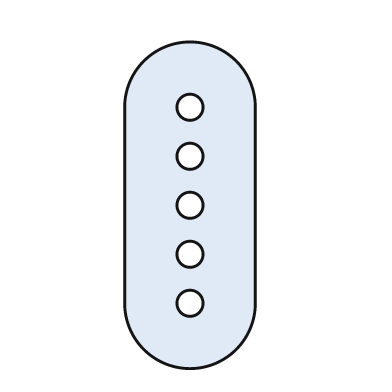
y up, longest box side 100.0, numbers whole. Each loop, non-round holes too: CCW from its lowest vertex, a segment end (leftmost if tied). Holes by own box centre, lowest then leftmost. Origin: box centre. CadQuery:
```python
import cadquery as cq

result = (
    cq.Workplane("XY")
    .moveTo(-20.0, -30.0)
    .threePointArc((0.0, -50.0), (20.0, -30.0))
    .lineTo(20.0, 30.0)
    .threePointArc((0.0, 50.0), (-20.0, 30.0))
    .close()
    .moveTo(0.0, -30.0)
    .circle(4.0)
    .moveTo(0.0, -15.0)
    .circle(4.0)
    .moveTo(0.0, 0.0)
    .circle(4.0)
    .moveTo(0.0, 15.0)
    .circle(4.0)
    .moveTo(0.0, 30.0)
    .circle(4.0)
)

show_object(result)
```